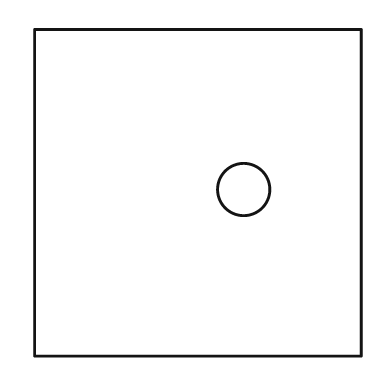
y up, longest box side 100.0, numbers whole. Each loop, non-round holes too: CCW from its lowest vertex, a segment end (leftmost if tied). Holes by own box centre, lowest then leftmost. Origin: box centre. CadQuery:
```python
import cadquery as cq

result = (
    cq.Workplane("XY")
    .moveTo(-50.0, -50.0)
    .lineTo(50.0, -50.0)
    .lineTo(50.0, 50.0)
    .lineTo(-50.0, 50.0)
    .close()
    .moveTo(14.0, 1.0)
    .circle(8.0)
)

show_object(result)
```